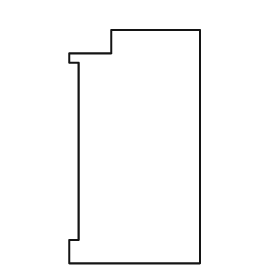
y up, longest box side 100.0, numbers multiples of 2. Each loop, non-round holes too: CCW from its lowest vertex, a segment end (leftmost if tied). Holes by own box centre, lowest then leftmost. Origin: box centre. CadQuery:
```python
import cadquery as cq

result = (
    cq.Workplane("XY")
    .moveTo(-28.0, -50.0)
    .lineTo(28.0, -50.0)
    .lineTo(28.0, 50.0)
    .lineTo(-10.0, 50.0)
    .lineTo(-10.0, 40.0)
    .lineTo(-28.0, 40.0)
    .lineTo(-28.0, 36.0)
    .lineTo(-24.0, 36.0)
    .lineTo(-24.0, -40.0)
    .lineTo(-28.0, -40.0)
    .close()
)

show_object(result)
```